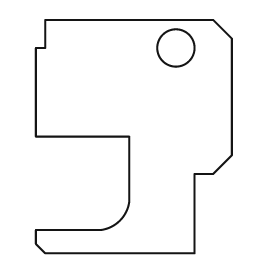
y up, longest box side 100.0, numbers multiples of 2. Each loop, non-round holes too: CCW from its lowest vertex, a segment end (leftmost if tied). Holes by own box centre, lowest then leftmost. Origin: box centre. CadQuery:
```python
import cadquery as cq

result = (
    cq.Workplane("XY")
    .moveTo(-38.0, -50.0)
    .lineTo(26.0, -50.0)
    .lineTo(26.0, -16.0)
    .lineTo(34.0, -16.0)
    .lineTo(42.0, -8.0)
    .lineTo(42.0, 42.0)
    .lineTo(34.0, 50.0)
    .lineTo(-38.0, 50.0)
    .lineTo(-38.0, 38.0)
    .lineTo(-42.0, 38.0)
    .lineTo(-42.0, 0.0)
    .lineTo(-2.0, 0.0)
    .lineTo(-2.0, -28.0)
    .threePointArc((-6.0, -36.0), (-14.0, -40.0))
    .lineTo(-42.0, -40.0)
    .lineTo(-42.0, -46.0)
    .close()
    .moveTo(18.0, 38.0)
    .circle(8.0)
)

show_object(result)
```